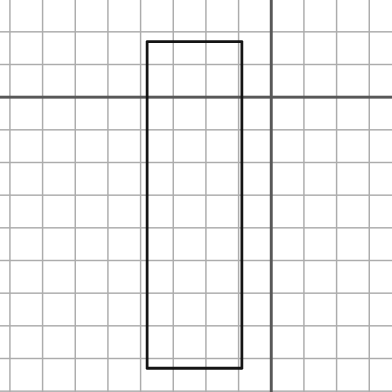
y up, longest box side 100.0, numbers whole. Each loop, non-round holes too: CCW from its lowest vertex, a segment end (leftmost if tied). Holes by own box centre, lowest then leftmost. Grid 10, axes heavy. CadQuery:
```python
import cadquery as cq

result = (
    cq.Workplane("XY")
    .moveTo(-38.0, -83.0)
    .lineTo(-9.0, -83.0)
    .lineTo(-9.0, 17.0)
    .lineTo(-38.0, 17.0)
    .close()
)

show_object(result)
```